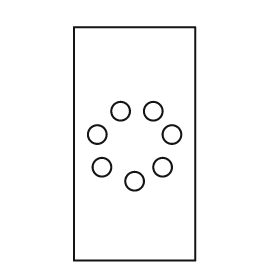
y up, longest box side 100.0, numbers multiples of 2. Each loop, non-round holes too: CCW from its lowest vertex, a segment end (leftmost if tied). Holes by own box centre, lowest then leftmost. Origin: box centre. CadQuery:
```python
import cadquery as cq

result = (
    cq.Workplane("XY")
    .moveTo(-26.0, -50.0)
    .lineTo(26.0, -50.0)
    .lineTo(26.0, 50.0)
    .lineTo(-26.0, 50.0)
    .close()
    .moveTo(0.0, -16.0)
    .circle(4.0)
    .moveTo(-14.0, -10.0)
    .circle(4.0)
    .moveTo(12.0, -10.0)
    .circle(4.0)
    .moveTo(-16.0, 4.0)
    .circle(4.0)
    .moveTo(16.0, 4.0)
    .circle(4.0)
    .moveTo(-6.0, 14.0)
    .circle(4.0)
    .moveTo(8.0, 14.0)
    .circle(4.0)
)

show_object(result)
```